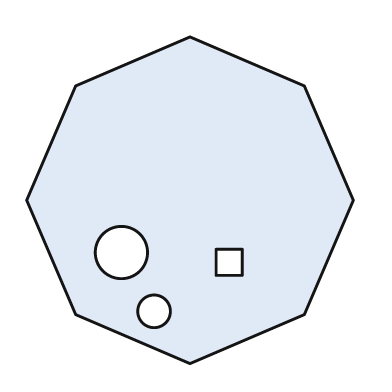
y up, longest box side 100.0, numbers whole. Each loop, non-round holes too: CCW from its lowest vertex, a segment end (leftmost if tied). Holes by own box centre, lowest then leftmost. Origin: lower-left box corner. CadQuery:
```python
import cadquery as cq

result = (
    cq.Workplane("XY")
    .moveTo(50.0, 0.0)
    .lineTo(85.0, 15.0)
    .lineTo(100.0, 50.0)
    .lineTo(85.0, 85.0)
    .lineTo(50.0, 100.0)
    .lineTo(15.0, 85.0)
    .lineTo(0.0, 50.0)
    .lineTo(15.0, 15.0)
    .close()
    .moveTo(39.0, 16.0)
    .circle(5.0)
    .moveTo(58.0, 27.0)
    .lineTo(66.0, 27.0)
    .lineTo(66.0, 35.0)
    .lineTo(58.0, 35.0)
    .close()
    .moveTo(29.0, 34.0)
    .circle(8.0)
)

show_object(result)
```